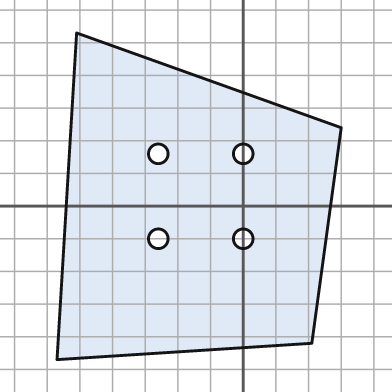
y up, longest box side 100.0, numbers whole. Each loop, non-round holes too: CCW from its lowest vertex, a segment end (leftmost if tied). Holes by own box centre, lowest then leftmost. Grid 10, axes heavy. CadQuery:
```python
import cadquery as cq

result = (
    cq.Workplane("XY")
    .moveTo(-57.0, -47.0)
    .lineTo(21.0, -42.0)
    .lineTo(30.0, 24.0)
    .lineTo(-51.0, 53.0)
    .close()
    .moveTo(-26.0, -10.0)
    .circle(3.0)
    .moveTo(0.0, -10.0)
    .circle(3.0)
    .moveTo(-26.0, 16.0)
    .circle(3.0)
    .moveTo(0.0, 16.0)
    .circle(3.0)
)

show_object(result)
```